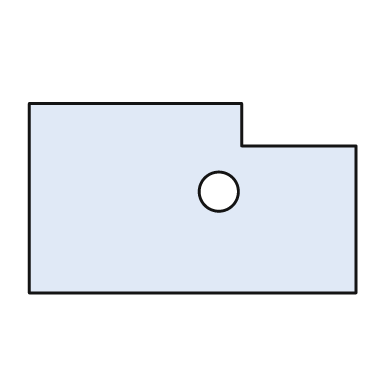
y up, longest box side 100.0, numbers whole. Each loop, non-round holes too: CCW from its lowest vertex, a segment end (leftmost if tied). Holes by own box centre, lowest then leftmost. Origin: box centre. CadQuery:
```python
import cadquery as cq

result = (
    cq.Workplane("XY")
    .moveTo(-50.0, -29.0)
    .lineTo(50.0, -29.0)
    .lineTo(50.0, 16.0)
    .lineTo(15.0, 16.0)
    .lineTo(15.0, 29.0)
    .lineTo(-50.0, 29.0)
    .close()
    .moveTo(8.0, 2.0)
    .circle(6.0)
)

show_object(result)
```